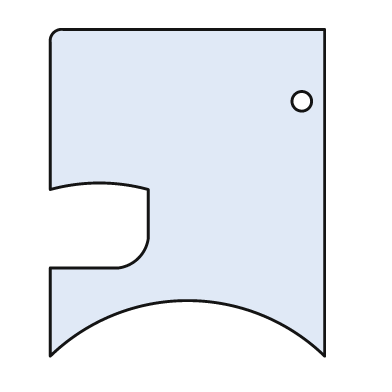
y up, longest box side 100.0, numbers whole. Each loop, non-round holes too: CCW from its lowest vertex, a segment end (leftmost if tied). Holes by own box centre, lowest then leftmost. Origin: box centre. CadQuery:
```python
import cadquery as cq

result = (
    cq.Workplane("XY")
    .moveTo(-42.0, -50.0)
    .threePointArc((0.0, -33.0), (42.0, -50.0))
    .lineTo(42.0, 50.0)
    .lineTo(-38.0, 50.0)
    .threePointArc((-41.0, 49.0), (-42.0, 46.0))
    .lineTo(-42.0, 1.0)
    .threePointArc((-27.0, 3.0), (-12.0, 1.0))
    .lineTo(-12.0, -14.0)
    .threePointArc((-15.0, -20.0), (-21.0, -23.0))
    .lineTo(-42.0, -23.0)
    .close()
    .moveTo(35.0, 28.0)
    .circle(3.0)
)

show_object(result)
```